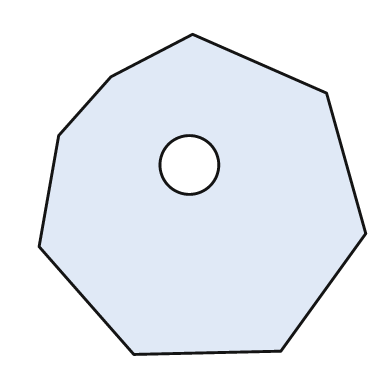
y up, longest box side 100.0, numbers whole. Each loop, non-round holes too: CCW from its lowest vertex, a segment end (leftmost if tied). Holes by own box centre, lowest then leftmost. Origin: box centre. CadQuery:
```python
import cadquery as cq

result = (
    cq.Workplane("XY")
    .moveTo(-21.0, -49.0)
    .lineTo(24.0, -48.0)
    .lineTo(50.0, -12.0)
    .lineTo(38.0, 31.0)
    .lineTo(-3.0, 49.0)
    .lineTo(-28.0, 36.0)
    .lineTo(-44.0, 18.0)
    .lineTo(-50.0, -16.0)
    .close()
    .moveTo(-4.0, 9.0)
    .circle(9.0)
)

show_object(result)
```